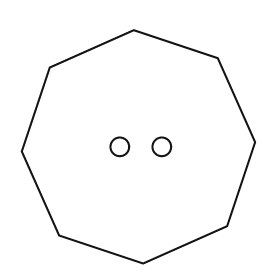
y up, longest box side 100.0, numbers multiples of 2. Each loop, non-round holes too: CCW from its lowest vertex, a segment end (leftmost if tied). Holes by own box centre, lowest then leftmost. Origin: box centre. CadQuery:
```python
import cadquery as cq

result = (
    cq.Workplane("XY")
    .moveTo(2.0, -50.0)
    .lineTo(38.0, -34.0)
    .lineTo(50.0, 2.0)
    .lineTo(34.0, 38.0)
    .lineTo(-2.0, 50.0)
    .lineTo(-38.0, 34.0)
    .lineTo(-50.0, -2.0)
    .lineTo(-34.0, -38.0)
    .close()
    .moveTo(-8.0, 0.0)
    .circle(4.0)
    .moveTo(10.0, 0.0)
    .circle(4.0)
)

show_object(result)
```